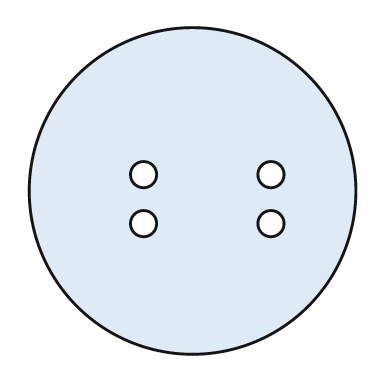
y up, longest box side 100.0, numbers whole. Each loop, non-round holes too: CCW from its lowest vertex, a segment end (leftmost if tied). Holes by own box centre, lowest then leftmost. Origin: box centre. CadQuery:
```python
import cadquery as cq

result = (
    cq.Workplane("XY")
    .moveTo(0.0, 0.0)
    .circle(50.0)
    .moveTo(-15.0, -10.0)
    .circle(4.0)
    .moveTo(24.0, -10.0)
    .circle(4.0)
    .moveTo(-15.0, 5.0)
    .circle(4.0)
    .moveTo(24.0, 5.0)
    .circle(4.0)
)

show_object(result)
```